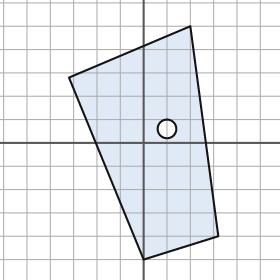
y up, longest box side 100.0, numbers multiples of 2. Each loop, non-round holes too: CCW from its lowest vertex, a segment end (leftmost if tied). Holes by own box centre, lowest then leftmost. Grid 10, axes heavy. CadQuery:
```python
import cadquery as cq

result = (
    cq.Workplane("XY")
    .moveTo(0.0, -50.0)
    .lineTo(32.0, -40.0)
    .lineTo(20.0, 50.0)
    .lineTo(-32.0, 28.0)
    .close()
    .moveTo(10.0, 6.0)
    .circle(4.0)
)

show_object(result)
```